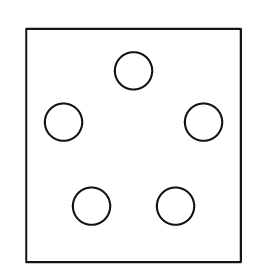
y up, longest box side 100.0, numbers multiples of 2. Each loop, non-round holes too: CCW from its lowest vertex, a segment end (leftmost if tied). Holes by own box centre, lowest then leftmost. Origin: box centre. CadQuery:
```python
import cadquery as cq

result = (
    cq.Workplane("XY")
    .moveTo(-46.0, -50.0)
    .lineTo(46.0, -50.0)
    .lineTo(46.0, 50.0)
    .lineTo(-46.0, 50.0)
    .close()
    .moveTo(-18.0, -26.0)
    .circle(8.0)
    .moveTo(18.0, -26.0)
    .circle(8.0)
    .moveTo(-30.0, 10.0)
    .circle(8.0)
    .moveTo(30.0, 10.0)
    .circle(8.0)
    .moveTo(0.0, 32.0)
    .circle(8.0)
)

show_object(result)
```